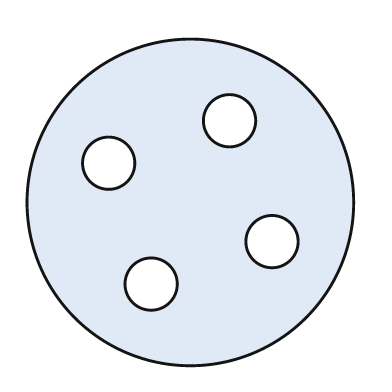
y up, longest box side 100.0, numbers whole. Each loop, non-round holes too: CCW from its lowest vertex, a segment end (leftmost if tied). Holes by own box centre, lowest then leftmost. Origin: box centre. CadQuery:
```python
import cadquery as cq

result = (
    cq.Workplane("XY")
    .moveTo(0.0, 0.0)
    .circle(50.0)
    .moveTo(-12.0, -25.0)
    .circle(8.0)
    .moveTo(25.0, -12.0)
    .circle(8.0)
    .moveTo(-25.0, 12.0)
    .circle(8.0)
    .moveTo(12.0, 25.0)
    .circle(8.0)
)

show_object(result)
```